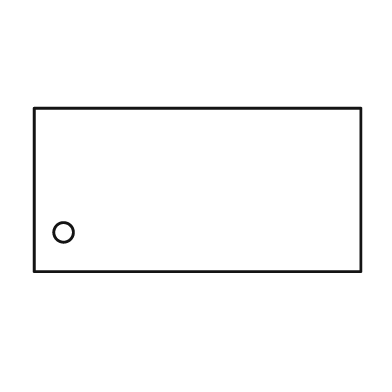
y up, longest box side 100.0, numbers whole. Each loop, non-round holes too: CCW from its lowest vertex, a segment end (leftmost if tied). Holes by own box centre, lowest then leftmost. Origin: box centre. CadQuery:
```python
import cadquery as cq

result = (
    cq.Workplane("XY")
    .moveTo(-50.0, -25.0)
    .lineTo(50.0, -25.0)
    .lineTo(50.0, 25.0)
    .lineTo(-50.0, 25.0)
    .close()
    .moveTo(-41.0, -13.0)
    .circle(3.0)
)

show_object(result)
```